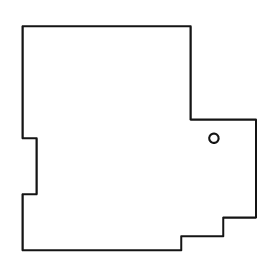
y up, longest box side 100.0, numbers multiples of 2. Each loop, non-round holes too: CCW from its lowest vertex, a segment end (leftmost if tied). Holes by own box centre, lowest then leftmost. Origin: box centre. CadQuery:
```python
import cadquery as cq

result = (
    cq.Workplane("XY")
    .moveTo(-50.0, -48.0)
    .lineTo(18.0, -48.0)
    .lineTo(18.0, -42.0)
    .lineTo(36.0, -42.0)
    .lineTo(36.0, -34.0)
    .lineTo(50.0, -34.0)
    .lineTo(50.0, 8.0)
    .lineTo(22.0, 8.0)
    .lineTo(22.0, 48.0)
    .lineTo(-50.0, 48.0)
    .lineTo(-50.0, 0.0)
    .lineTo(-44.0, 0.0)
    .lineTo(-44.0, -24.0)
    .lineTo(-50.0, -24.0)
    .close()
    .moveTo(32.0, 0.0)
    .circle(2.0)
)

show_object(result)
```